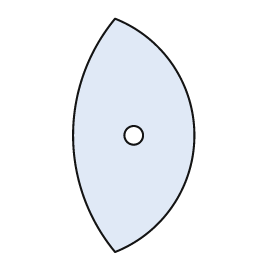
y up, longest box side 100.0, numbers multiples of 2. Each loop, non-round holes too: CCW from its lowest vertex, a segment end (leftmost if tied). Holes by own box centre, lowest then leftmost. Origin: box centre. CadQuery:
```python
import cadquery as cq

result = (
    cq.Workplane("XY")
    .moveTo(-8.0, -50.0)
    .threePointArc((26.0, 0.0), (-8.0, 50.0))
    .threePointArc((-26.0, 0.0), (-8.0, -50.0))
    .close()
    .moveTo(0.0, 0.0)
    .circle(4.0)
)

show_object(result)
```